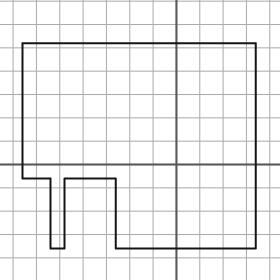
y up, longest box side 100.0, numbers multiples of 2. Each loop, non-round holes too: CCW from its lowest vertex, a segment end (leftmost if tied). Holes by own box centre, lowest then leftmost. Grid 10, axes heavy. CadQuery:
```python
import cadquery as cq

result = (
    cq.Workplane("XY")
    .moveTo(-54.0, -36.0)
    .lineTo(-48.0, -36.0)
    .lineTo(-48.0, -6.0)
    .lineTo(-26.0, -6.0)
    .lineTo(-26.0, -36.0)
    .lineTo(34.0, -36.0)
    .lineTo(34.0, 52.0)
    .lineTo(-66.0, 52.0)
    .lineTo(-66.0, -6.0)
    .lineTo(-54.0, -6.0)
    .close()
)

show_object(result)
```